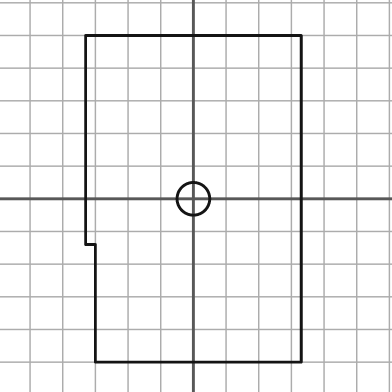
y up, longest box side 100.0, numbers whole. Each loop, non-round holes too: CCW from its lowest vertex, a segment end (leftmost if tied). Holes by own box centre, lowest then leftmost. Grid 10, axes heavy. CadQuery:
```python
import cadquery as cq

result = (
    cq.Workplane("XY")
    .moveTo(-30.0, -50.0)
    .lineTo(33.0, -50.0)
    .lineTo(33.0, 50.0)
    .lineTo(-33.0, 50.0)
    .lineTo(-33.0, -14.0)
    .lineTo(-30.0, -14.0)
    .close()
    .moveTo(0.0, 0.0)
    .circle(5.0)
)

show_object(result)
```